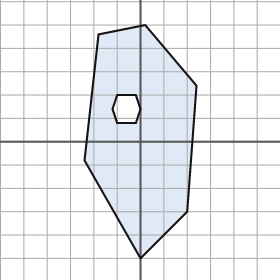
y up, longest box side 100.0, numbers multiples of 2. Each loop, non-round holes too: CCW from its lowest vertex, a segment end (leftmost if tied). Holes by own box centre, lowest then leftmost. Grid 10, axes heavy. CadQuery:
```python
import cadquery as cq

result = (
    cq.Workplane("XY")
    .moveTo(0.0, -50.0)
    .lineTo(20.0, -30.0)
    .lineTo(24.0, 24.0)
    .lineTo(2.0, 50.0)
    .lineTo(-18.0, 46.0)
    .lineTo(-24.0, -8.0)
    .close()
    .moveTo(-10.0, 8.0)
    .lineTo(-2.0, 8.0)
    .lineTo(0.0, 14.0)
    .lineTo(-2.0, 20.0)
    .lineTo(-10.0, 20.0)
    .lineTo(-12.0, 14.0)
    .close()
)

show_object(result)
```